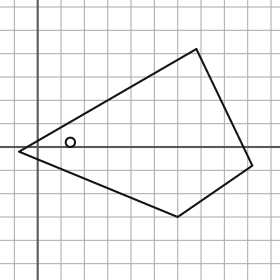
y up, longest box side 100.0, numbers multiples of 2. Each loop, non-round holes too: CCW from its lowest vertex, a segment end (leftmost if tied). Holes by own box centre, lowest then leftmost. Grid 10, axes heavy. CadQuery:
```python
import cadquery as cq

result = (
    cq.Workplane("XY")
    .moveTo(60.0, -30.0)
    .lineTo(92.0, -8.0)
    .lineTo(68.0, 42.0)
    .lineTo(-8.0, -2.0)
    .close()
    .moveTo(14.0, 2.0)
    .circle(2.0)
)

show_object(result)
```